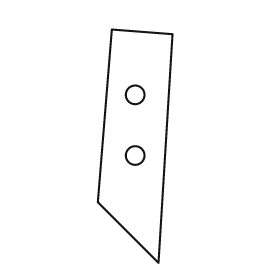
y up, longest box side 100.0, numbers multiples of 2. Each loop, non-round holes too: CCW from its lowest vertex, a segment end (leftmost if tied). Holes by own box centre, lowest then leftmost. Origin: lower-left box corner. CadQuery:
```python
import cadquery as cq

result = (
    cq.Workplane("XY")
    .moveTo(26.0, 0.0)
    .lineTo(32.0, 98.0)
    .lineTo(6.0, 100.0)
    .lineTo(0.0, 26.0)
    .close()
    .moveTo(16.0, 46.0)
    .circle(4.0)
    .moveTo(16.0, 72.0)
    .circle(4.0)
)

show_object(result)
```